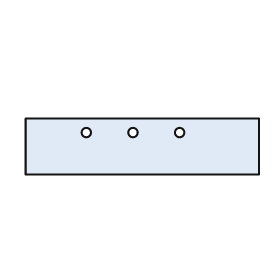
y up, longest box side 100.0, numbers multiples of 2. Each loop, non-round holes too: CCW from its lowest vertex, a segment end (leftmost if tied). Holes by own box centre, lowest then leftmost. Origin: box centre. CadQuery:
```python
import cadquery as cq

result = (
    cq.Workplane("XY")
    .moveTo(-50.0, -12.0)
    .lineTo(50.0, -12.0)
    .lineTo(50.0, 12.0)
    .lineTo(-50.0, 12.0)
    .close()
    .moveTo(-24.0, 6.0)
    .circle(2.0)
    .moveTo(-4.0, 6.0)
    .circle(2.0)
    .moveTo(16.0, 6.0)
    .circle(2.0)
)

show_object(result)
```